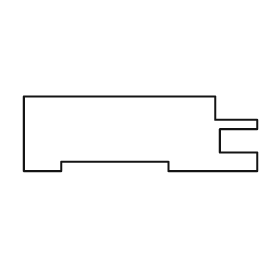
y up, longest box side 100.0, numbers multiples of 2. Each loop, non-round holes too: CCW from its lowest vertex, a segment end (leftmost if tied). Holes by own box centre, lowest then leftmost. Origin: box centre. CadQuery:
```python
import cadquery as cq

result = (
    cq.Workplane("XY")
    .moveTo(-50.0, -16.0)
    .lineTo(-34.0, -16.0)
    .lineTo(-34.0, -12.0)
    .lineTo(12.0, -12.0)
    .lineTo(12.0, -16.0)
    .lineTo(50.0, -16.0)
    .lineTo(50.0, -8.0)
    .lineTo(34.0, -8.0)
    .lineTo(34.0, 2.0)
    .lineTo(50.0, 2.0)
    .lineTo(50.0, 6.0)
    .lineTo(32.0, 6.0)
    .lineTo(32.0, 16.0)
    .lineTo(-50.0, 16.0)
    .close()
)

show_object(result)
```